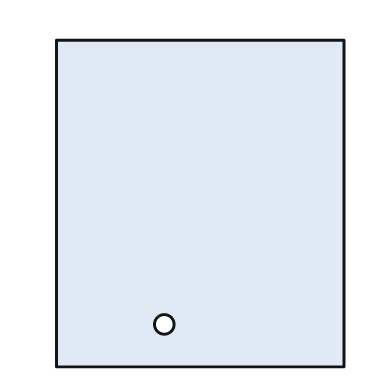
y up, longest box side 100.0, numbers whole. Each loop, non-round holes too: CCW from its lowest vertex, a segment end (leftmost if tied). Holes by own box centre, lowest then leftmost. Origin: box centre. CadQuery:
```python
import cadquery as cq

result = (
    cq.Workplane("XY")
    .moveTo(-44.0, -50.0)
    .lineTo(44.0, -50.0)
    .lineTo(44.0, 50.0)
    .lineTo(-44.0, 50.0)
    .close()
    .moveTo(-11.0, -37.0)
    .circle(3.0)
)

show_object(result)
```